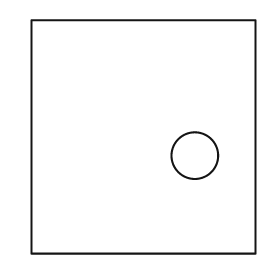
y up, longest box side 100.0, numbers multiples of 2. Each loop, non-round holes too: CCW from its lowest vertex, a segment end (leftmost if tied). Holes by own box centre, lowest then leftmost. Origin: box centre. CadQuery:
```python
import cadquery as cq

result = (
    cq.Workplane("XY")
    .moveTo(-48.0, -50.0)
    .lineTo(48.0, -50.0)
    .lineTo(48.0, 50.0)
    .lineTo(-48.0, 50.0)
    .close()
    .moveTo(22.0, -8.0)
    .circle(10.0)
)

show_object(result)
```